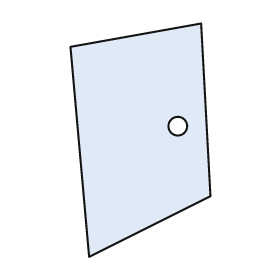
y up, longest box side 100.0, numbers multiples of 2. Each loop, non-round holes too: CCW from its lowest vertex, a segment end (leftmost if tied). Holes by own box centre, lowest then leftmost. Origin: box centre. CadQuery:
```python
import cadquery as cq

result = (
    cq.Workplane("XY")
    .moveTo(-22.0, -50.0)
    .lineTo(30.0, -24.0)
    .lineTo(26.0, 50.0)
    .lineTo(-30.0, 40.0)
    .close()
    .moveTo(16.0, 6.0)
    .circle(4.0)
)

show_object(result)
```